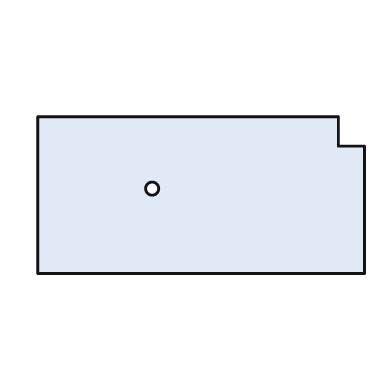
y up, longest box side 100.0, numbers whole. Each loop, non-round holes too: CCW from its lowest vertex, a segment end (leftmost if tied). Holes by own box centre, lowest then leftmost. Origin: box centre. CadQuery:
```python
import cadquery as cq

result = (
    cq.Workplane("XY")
    .moveTo(-50.0, -24.0)
    .lineTo(50.0, -24.0)
    .lineTo(50.0, 15.0)
    .lineTo(42.0, 15.0)
    .lineTo(42.0, 24.0)
    .lineTo(-50.0, 24.0)
    .close()
    .moveTo(-15.0, 2.0)
    .circle(2.0)
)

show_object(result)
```